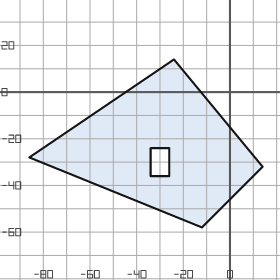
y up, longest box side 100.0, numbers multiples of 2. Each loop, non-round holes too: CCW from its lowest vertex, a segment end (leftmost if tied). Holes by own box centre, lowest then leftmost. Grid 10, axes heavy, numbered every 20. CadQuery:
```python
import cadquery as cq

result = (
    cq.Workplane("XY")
    .moveTo(-12.0, -58.0)
    .lineTo(14.0, -32.0)
    .lineTo(-24.0, 14.0)
    .lineTo(-86.0, -28.0)
    .close()
    .moveTo(-34.0, -36.0)
    .lineTo(-26.0, -36.0)
    .lineTo(-26.0, -24.0)
    .lineTo(-34.0, -24.0)
    .close()
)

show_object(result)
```